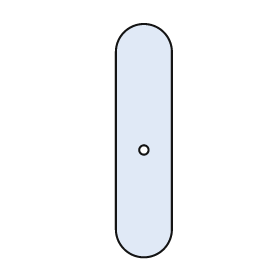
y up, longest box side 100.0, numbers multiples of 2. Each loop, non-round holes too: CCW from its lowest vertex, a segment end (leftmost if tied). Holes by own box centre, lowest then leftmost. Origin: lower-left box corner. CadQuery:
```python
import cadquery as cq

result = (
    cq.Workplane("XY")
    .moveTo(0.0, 12.0)
    .threePointArc((12.0, 0.0), (24.0, 12.0))
    .lineTo(24.0, 88.0)
    .threePointArc((12.0, 100.0), (0.0, 88.0))
    .close()
    .moveTo(12.0, 46.0)
    .circle(2.0)
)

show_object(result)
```